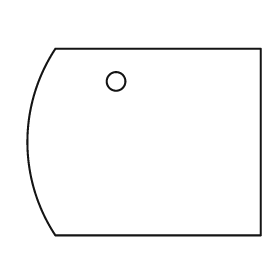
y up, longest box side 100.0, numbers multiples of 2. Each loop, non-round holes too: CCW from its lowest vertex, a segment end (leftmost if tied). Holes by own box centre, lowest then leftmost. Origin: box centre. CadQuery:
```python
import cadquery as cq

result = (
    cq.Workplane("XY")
    .moveTo(-38.0, -40.0)
    .lineTo(50.0, -40.0)
    .lineTo(50.0, 40.0)
    .lineTo(-38.0, 40.0)
    .threePointArc((-50.0, 0.0), (-38.0, -40.0))
    .close()
    .moveTo(-12.0, 26.0)
    .circle(4.0)
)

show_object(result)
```